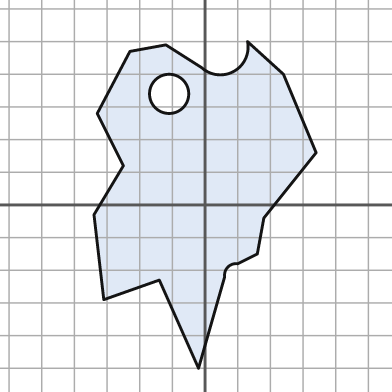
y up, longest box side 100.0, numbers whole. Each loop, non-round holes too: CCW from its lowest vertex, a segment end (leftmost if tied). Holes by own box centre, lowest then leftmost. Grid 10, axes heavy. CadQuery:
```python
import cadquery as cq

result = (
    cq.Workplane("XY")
    .moveTo(-2.0, -50.0)
    .lineTo(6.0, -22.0)
    .threePointArc((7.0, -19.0), (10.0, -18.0))
    .lineTo(16.0, -15.0)
    .lineTo(18.0, -4.0)
    .lineTo(34.0, 16.0)
    .lineTo(24.0, 40.0)
    .lineTo(13.0, 50.0)
    .threePointArc((9.0, 41.0), (-1.0, 42.0))
    .lineTo(-12.0, 49.0)
    .lineTo(-23.0, 47.0)
    .lineTo(-33.0, 28.0)
    .lineTo(-25.0, 12.0)
    .lineTo(-34.0, -3.0)
    .lineTo(-31.0, -29.0)
    .lineTo(-14.0, -23.0)
    .close()
    .moveTo(-11.0, 34.0)
    .circle(6.0)
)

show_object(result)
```